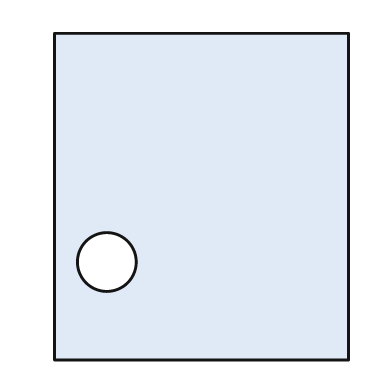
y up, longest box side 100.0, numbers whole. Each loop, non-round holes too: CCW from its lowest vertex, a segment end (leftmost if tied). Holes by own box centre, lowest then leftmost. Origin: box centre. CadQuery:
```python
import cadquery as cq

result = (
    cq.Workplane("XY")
    .moveTo(-45.0, -50.0)
    .lineTo(45.0, -50.0)
    .lineTo(45.0, 50.0)
    .lineTo(-45.0, 50.0)
    .close()
    .moveTo(-29.0, -20.0)
    .circle(9.0)
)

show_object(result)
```